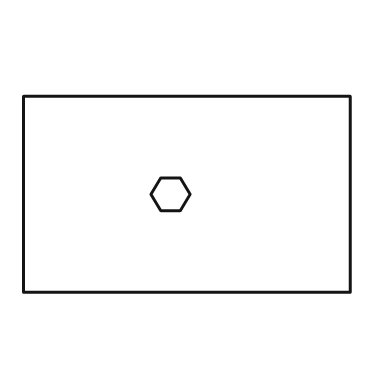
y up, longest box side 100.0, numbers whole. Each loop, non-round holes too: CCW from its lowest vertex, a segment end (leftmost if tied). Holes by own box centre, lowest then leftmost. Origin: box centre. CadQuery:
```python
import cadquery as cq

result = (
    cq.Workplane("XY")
    .moveTo(-50.0, -30.0)
    .lineTo(50.0, -30.0)
    .lineTo(50.0, 30.0)
    .lineTo(-50.0, 30.0)
    .close()
    .moveTo(-8.0, -5.0)
    .lineTo(-2.0, -5.0)
    .lineTo(1.0, 0.0)
    .lineTo(-2.0, 5.0)
    .lineTo(-8.0, 5.0)
    .lineTo(-11.0, 0.0)
    .close()
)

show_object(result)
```